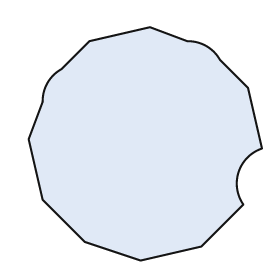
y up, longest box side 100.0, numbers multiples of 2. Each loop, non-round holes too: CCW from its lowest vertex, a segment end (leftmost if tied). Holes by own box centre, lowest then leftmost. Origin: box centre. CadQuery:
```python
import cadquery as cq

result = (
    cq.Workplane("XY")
    .moveTo(-2.0, -50.0)
    .lineTo(24.0, -44.0)
    .lineTo(42.0, -26.0)
    .threePointArc((40.0, -12.0), (50.0, -2.0))
    .lineTo(44.0, 24.0)
    .lineTo(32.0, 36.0)
    .threePointArc((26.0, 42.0), (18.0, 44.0))
    .lineTo(2.0, 50.0)
    .lineTo(-24.0, 44.0)
    .lineTo(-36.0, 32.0)
    .threePointArc((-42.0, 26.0), (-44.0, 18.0))
    .lineTo(-50.0, 2.0)
    .lineTo(-44.0, -24.0)
    .lineTo(-26.0, -42.0)
    .close()
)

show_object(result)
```